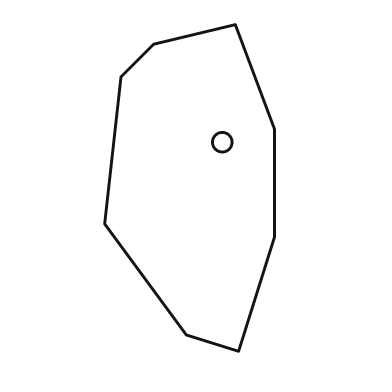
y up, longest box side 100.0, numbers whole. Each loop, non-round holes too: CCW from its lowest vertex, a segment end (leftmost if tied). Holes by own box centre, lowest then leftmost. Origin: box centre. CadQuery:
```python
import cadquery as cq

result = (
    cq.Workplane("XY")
    .moveTo(15.0, -50.0)
    .lineTo(26.0, -15.0)
    .lineTo(26.0, 18.0)
    .lineTo(14.0, 50.0)
    .lineTo(-11.0, 44.0)
    .lineTo(-21.0, 34.0)
    .lineTo(-26.0, -11.0)
    .lineTo(-1.0, -45.0)
    .close()
    .moveTo(10.0, 14.0)
    .circle(3.0)
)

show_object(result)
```